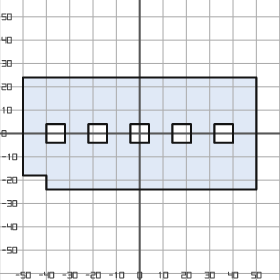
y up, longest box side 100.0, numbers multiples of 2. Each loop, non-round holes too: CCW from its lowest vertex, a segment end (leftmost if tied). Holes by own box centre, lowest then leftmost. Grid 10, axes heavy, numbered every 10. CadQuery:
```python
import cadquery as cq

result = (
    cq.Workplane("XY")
    .moveTo(-40.0, -24.0)
    .lineTo(50.0, -24.0)
    .lineTo(50.0, 24.0)
    .lineTo(-50.0, 24.0)
    .lineTo(-50.0, -18.0)
    .lineTo(-40.0, -18.0)
    .close()
    .moveTo(-40.0, -4.0)
    .lineTo(-32.0, -4.0)
    .lineTo(-32.0, 4.0)
    .lineTo(-40.0, 4.0)
    .close()
    .moveTo(-22.0, -4.0)
    .lineTo(-14.0, -4.0)
    .lineTo(-14.0, 4.0)
    .lineTo(-22.0, 4.0)
    .close()
    .moveTo(-4.0, -4.0)
    .lineTo(4.0, -4.0)
    .lineTo(4.0, 4.0)
    .lineTo(-4.0, 4.0)
    .close()
    .moveTo(14.0, -4.0)
    .lineTo(22.0, -4.0)
    .lineTo(22.0, 4.0)
    .lineTo(14.0, 4.0)
    .close()
    .moveTo(32.0, -4.0)
    .lineTo(40.0, -4.0)
    .lineTo(40.0, 4.0)
    .lineTo(32.0, 4.0)
    .close()
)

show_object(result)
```